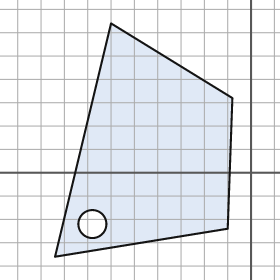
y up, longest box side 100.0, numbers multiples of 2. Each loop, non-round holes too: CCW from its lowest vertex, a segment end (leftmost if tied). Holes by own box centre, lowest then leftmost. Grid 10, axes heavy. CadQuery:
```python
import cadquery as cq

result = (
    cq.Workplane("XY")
    .moveTo(-84.0, -36.0)
    .lineTo(-10.0, -24.0)
    .lineTo(-8.0, 32.0)
    .lineTo(-60.0, 64.0)
    .close()
    .moveTo(-68.0, -22.0)
    .circle(6.0)
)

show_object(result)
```